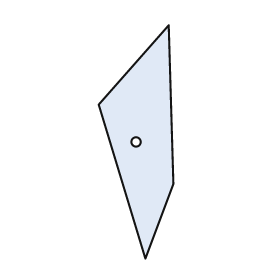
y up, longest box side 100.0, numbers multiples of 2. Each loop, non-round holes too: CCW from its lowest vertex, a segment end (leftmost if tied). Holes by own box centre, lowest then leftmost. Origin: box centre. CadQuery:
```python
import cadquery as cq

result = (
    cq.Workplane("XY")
    .moveTo(4.0, -50.0)
    .lineTo(16.0, -18.0)
    .lineTo(14.0, 50.0)
    .lineTo(-16.0, 16.0)
    .close()
    .moveTo(0.0, 0.0)
    .circle(2.0)
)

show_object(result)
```